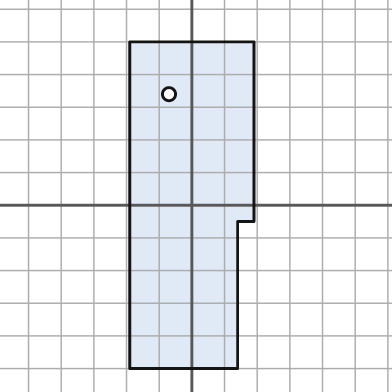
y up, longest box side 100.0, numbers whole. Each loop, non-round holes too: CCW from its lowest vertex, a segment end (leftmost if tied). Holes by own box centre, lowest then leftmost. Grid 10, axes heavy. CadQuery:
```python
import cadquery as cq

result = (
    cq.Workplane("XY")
    .moveTo(-19.0, -50.0)
    .lineTo(14.0, -50.0)
    .lineTo(14.0, -5.0)
    .lineTo(19.0, -5.0)
    .lineTo(19.0, 50.0)
    .lineTo(-19.0, 50.0)
    .close()
    .moveTo(-7.0, 34.0)
    .circle(2.0)
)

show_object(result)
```